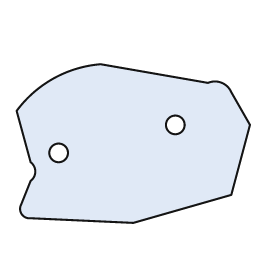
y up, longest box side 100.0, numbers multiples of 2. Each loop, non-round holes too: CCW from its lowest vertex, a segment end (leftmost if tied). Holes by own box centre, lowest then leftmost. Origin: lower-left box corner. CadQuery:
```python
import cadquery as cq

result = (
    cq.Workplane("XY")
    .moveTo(50.0, 0.0)
    .lineTo(92.0, 12.0)
    .lineTo(100.0, 42.0)
    .lineTo(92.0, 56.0)
    .threePointArc((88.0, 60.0), (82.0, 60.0))
    .lineTo(36.0, 68.0)
    .threePointArc((16.0, 62.0), (0.0, 48.0))
    .lineTo(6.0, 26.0)
    .threePointArc((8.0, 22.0), (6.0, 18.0))
    .lineTo(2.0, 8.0)
    .threePointArc((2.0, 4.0), (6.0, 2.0))
    .close()
    .moveTo(18.0, 30.0)
    .circle(4.0)
    .moveTo(68.0, 42.0)
    .circle(4.0)
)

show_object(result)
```